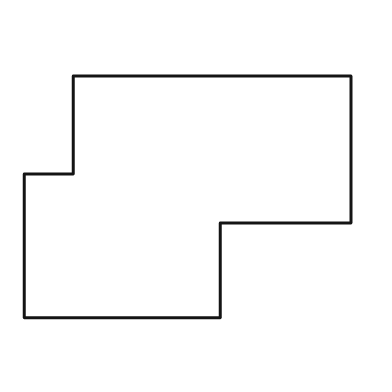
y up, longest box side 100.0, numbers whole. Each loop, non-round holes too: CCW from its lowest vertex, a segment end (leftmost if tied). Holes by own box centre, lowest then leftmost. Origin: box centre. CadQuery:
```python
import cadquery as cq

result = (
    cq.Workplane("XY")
    .moveTo(-50.0, -37.0)
    .lineTo(10.0, -37.0)
    .lineTo(10.0, -8.0)
    .lineTo(50.0, -8.0)
    .lineTo(50.0, 37.0)
    .lineTo(-35.0, 37.0)
    .lineTo(-35.0, 7.0)
    .lineTo(-50.0, 7.0)
    .close()
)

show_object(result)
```